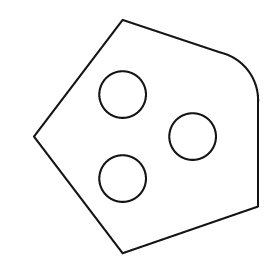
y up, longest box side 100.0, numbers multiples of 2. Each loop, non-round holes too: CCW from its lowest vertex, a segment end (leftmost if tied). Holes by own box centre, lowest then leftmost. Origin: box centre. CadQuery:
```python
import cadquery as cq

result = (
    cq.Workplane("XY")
    .moveTo(-10.0, -50.0)
    .lineTo(48.0, -30.0)
    .lineTo(48.0, 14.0)
    .threePointArc((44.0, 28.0), (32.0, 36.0))
    .lineTo(-10.0, 50.0)
    .lineTo(-48.0, 0.0)
    .close()
    .moveTo(-10.0, -18.0)
    .circle(10.0)
    .moveTo(20.0, 0.0)
    .circle(10.0)
    .moveTo(-10.0, 18.0)
    .circle(10.0)
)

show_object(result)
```